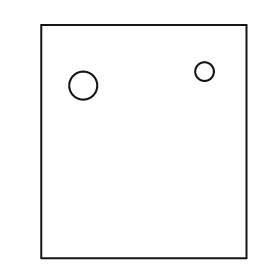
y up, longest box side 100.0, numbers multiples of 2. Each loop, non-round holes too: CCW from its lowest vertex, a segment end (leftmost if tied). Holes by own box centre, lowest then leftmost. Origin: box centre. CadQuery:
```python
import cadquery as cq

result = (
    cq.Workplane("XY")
    .moveTo(-44.0, -50.0)
    .lineTo(44.0, -50.0)
    .lineTo(44.0, 50.0)
    .lineTo(-44.0, 50.0)
    .close()
    .moveTo(-26.0, 24.0)
    .circle(6.0)
    .moveTo(26.0, 30.0)
    .circle(4.0)
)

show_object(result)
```